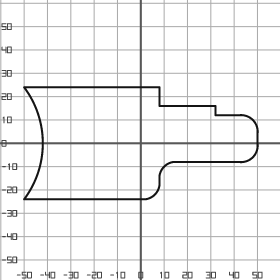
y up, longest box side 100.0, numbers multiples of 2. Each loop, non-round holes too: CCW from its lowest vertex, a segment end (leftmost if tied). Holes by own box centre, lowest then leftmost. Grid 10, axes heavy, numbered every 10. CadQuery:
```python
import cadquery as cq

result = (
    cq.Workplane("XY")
    .moveTo(-50.0, -24.0)
    .lineTo(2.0, -24.0)
    .threePointArc((6.0, -22.0), (8.0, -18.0))
    .lineTo(8.0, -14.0)
    .threePointArc((10.0, -10.0), (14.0, -8.0))
    .lineTo(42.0, -8.0)
    .threePointArc((48.0, -6.0), (50.0, 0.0))
    .lineTo(50.0, 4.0)
    .threePointArc((48.0, 10.0), (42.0, 12.0))
    .lineTo(32.0, 12.0)
    .lineTo(32.0, 16.0)
    .lineTo(8.0, 16.0)
    .lineTo(8.0, 24.0)
    .lineTo(-50.0, 24.0)
    .threePointArc((-42.0, 0.0), (-50.0, -24.0))
    .close()
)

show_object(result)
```